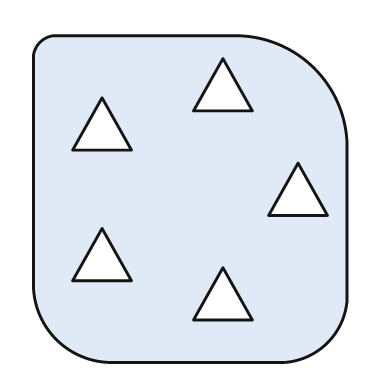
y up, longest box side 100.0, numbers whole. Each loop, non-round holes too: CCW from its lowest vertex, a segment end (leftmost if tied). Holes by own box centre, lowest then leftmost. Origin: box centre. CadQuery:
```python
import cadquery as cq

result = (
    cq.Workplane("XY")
    .moveTo(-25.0, -50.0)
    .lineTo(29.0, -50.0)
    .threePointArc((42.0, -44.0), (48.0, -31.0))
    .lineTo(48.0, 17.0)
    .threePointArc((38.0, 40.0), (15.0, 50.0))
    .lineTo(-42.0, 50.0)
    .threePointArc((-46.0, 48.0), (-48.0, 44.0))
    .lineTo(-48.0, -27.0)
    .threePointArc((-41.0, -43.0), (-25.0, -50.0))
    .close()
    .moveTo(1.0, -37.0)
    .lineTo(19.0, -37.0)
    .lineTo(10.0, -21.0)
    .close()
    .moveTo(-36.0, -25.0)
    .lineTo(-18.0, -25.0)
    .lineTo(-27.0, -9.0)
    .close()
    .moveTo(24.0, -5.0)
    .lineTo(42.0, -5.0)
    .lineTo(33.0, 11.0)
    .close()
    .moveTo(-36.0, 15.0)
    .lineTo(-18.0, 15.0)
    .lineTo(-27.0, 31.0)
    .close()
    .moveTo(1.0, 27.0)
    .lineTo(19.0, 27.0)
    .lineTo(10.0, 43.0)
    .close()
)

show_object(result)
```